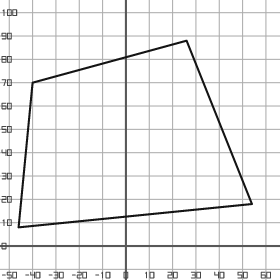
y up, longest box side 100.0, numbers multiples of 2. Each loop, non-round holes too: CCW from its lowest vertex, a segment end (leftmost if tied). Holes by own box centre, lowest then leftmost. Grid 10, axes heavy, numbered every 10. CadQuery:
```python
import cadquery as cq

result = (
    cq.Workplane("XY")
    .moveTo(-46.0, 8.0)
    .lineTo(54.0, 18.0)
    .lineTo(26.0, 88.0)
    .lineTo(-40.0, 70.0)
    .close()
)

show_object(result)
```